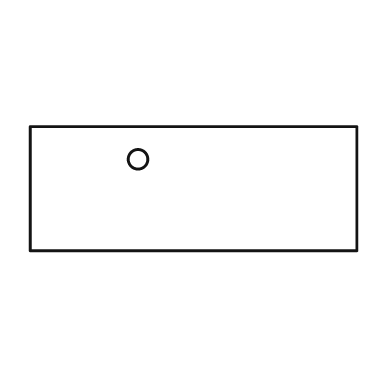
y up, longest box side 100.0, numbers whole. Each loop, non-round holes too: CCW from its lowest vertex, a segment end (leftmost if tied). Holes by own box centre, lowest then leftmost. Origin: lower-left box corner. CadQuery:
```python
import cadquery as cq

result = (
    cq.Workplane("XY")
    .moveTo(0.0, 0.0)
    .lineTo(100.0, 0.0)
    .lineTo(100.0, 38.0)
    .lineTo(0.0, 38.0)
    .close()
    .moveTo(33.0, 28.0)
    .circle(3.0)
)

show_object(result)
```